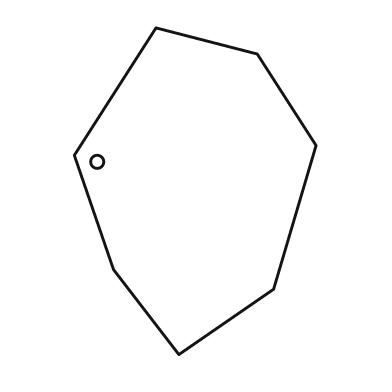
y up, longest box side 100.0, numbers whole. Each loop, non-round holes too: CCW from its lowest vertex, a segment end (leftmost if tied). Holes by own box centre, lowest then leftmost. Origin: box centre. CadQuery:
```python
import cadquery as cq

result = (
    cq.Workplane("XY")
    .moveTo(-5.0, -50.0)
    .lineTo(24.0, -30.0)
    .lineTo(37.0, 14.0)
    .lineTo(19.0, 42.0)
    .lineTo(-12.0, 50.0)
    .lineTo(-37.0, 11.0)
    .lineTo(-25.0, -24.0)
    .close()
    .moveTo(-30.0, 9.0)
    .circle(2.0)
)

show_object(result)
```